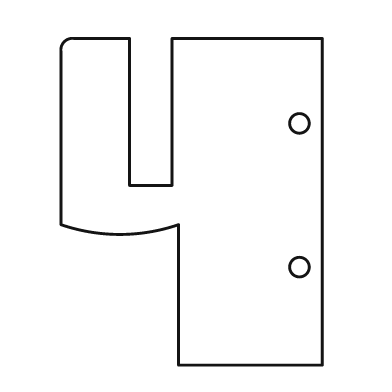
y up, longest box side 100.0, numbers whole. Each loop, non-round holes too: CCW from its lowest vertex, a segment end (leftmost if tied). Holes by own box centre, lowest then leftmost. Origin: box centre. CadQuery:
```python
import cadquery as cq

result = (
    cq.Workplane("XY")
    .moveTo(-4.0, -50.0)
    .lineTo(40.0, -50.0)
    .lineTo(40.0, 50.0)
    .lineTo(-6.0, 50.0)
    .lineTo(-6.0, 5.0)
    .lineTo(-19.0, 5.0)
    .lineTo(-19.0, 50.0)
    .lineTo(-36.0, 50.0)
    .threePointArc((-39.0, 49.0), (-40.0, 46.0))
    .lineTo(-40.0, -7.0)
    .threePointArc((-22.0, -10.0), (-4.0, -7.0))
    .close()
    .moveTo(33.0, -20.0)
    .circle(3.0)
    .moveTo(33.0, 24.0)
    .circle(3.0)
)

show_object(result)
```